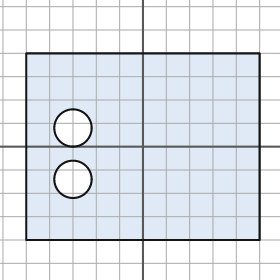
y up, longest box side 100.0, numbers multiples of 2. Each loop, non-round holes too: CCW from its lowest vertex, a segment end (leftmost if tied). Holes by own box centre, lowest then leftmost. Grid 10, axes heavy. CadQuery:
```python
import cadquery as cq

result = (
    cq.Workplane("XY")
    .moveTo(-50.0, -40.0)
    .lineTo(50.0, -40.0)
    .lineTo(50.0, 40.0)
    .lineTo(-50.0, 40.0)
    .close()
    .moveTo(-30.0, -14.0)
    .circle(8.0)
    .moveTo(-30.0, 8.0)
    .circle(8.0)
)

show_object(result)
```